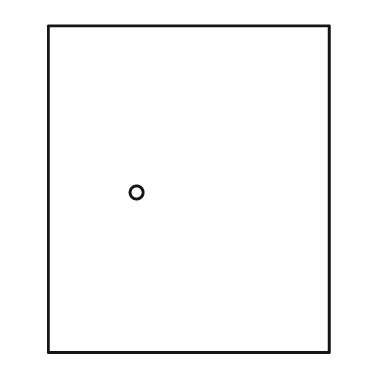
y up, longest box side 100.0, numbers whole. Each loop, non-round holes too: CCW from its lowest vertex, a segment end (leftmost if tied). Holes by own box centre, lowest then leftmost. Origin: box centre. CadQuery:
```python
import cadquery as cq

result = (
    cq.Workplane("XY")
    .moveTo(-43.0, -50.0)
    .lineTo(43.0, -50.0)
    .lineTo(43.0, 50.0)
    .lineTo(-43.0, 50.0)
    .close()
    .moveTo(-16.0, -1.0)
    .circle(2.0)
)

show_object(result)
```